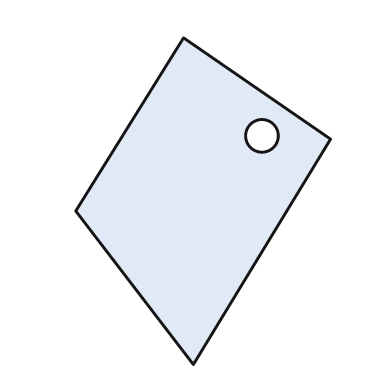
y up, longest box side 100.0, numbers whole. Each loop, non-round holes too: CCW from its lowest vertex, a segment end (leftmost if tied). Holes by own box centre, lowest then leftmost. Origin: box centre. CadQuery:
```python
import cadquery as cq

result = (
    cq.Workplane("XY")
    .moveTo(-3.0, -50.0)
    .lineTo(39.0, 19.0)
    .lineTo(-6.0, 50.0)
    .lineTo(-39.0, -3.0)
    .close()
    .moveTo(18.0, 20.0)
    .circle(5.0)
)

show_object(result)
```